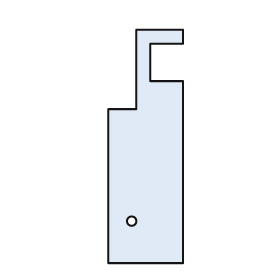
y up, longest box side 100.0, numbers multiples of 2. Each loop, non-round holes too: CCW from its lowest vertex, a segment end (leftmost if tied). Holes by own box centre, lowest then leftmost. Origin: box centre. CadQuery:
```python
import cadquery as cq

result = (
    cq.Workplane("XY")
    .moveTo(-16.0, -50.0)
    .lineTo(16.0, -50.0)
    .lineTo(16.0, 28.0)
    .lineTo(2.0, 28.0)
    .lineTo(2.0, 44.0)
    .lineTo(16.0, 44.0)
    .lineTo(16.0, 50.0)
    .lineTo(-4.0, 50.0)
    .lineTo(-4.0, 16.0)
    .lineTo(-16.0, 16.0)
    .close()
    .moveTo(-6.0, -32.0)
    .circle(2.0)
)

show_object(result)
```